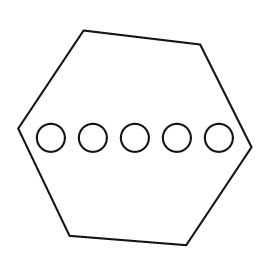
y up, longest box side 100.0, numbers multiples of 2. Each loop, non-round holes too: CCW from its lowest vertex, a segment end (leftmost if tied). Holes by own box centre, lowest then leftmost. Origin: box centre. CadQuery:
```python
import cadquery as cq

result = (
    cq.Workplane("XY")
    .moveTo(22.0, -46.0)
    .lineTo(50.0, -4.0)
    .lineTo(28.0, 40.0)
    .lineTo(-22.0, 46.0)
    .lineTo(-50.0, 4.0)
    .lineTo(-28.0, -42.0)
    .close()
    .moveTo(-36.0, 0.0)
    .circle(6.0)
    .moveTo(-18.0, 0.0)
    .circle(6.0)
    .moveTo(0.0, 0.0)
    .circle(6.0)
    .moveTo(18.0, 0.0)
    .circle(6.0)
    .moveTo(36.0, 0.0)
    .circle(6.0)
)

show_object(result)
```